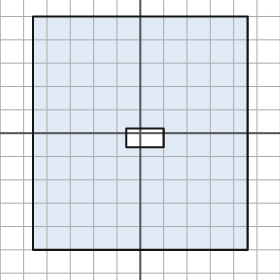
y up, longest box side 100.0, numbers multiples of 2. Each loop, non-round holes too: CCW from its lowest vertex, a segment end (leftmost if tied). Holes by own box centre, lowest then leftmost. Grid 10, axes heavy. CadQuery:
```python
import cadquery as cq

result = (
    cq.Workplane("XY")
    .moveTo(-46.0, -50.0)
    .lineTo(46.0, -50.0)
    .lineTo(46.0, 50.0)
    .lineTo(-46.0, 50.0)
    .close()
    .moveTo(-6.0, -6.0)
    .lineTo(10.0, -6.0)
    .lineTo(10.0, 2.0)
    .lineTo(-6.0, 2.0)
    .close()
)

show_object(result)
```